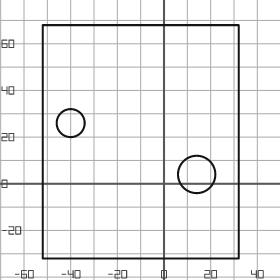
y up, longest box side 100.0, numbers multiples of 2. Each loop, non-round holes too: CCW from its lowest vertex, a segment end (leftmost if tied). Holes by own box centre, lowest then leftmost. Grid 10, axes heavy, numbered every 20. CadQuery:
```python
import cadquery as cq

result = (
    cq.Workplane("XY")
    .moveTo(-52.0, -32.0)
    .lineTo(32.0, -32.0)
    .lineTo(32.0, 68.0)
    .lineTo(-52.0, 68.0)
    .close()
    .moveTo(14.0, 4.0)
    .circle(8.0)
    .moveTo(-40.0, 26.0)
    .circle(6.0)
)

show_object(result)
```